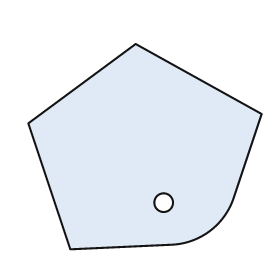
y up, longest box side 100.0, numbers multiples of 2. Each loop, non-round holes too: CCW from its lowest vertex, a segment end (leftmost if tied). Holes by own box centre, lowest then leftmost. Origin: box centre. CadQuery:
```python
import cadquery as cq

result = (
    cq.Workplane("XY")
    .moveTo(-32.0, -44.0)
    .lineTo(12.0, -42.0)
    .threePointArc((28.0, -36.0), (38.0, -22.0))
    .lineTo(50.0, 14.0)
    .lineTo(-4.0, 44.0)
    .lineTo(-50.0, 10.0)
    .close()
    .moveTo(8.0, -24.0)
    .circle(4.0)
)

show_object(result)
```